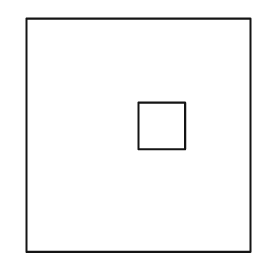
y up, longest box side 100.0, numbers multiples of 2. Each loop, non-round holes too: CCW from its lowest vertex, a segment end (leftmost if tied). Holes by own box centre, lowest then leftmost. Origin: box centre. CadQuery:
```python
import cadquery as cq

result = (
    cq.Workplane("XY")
    .moveTo(-48.0, -50.0)
    .lineTo(48.0, -50.0)
    .lineTo(48.0, 50.0)
    .lineTo(-48.0, 50.0)
    .close()
    .moveTo(0.0, -6.0)
    .lineTo(20.0, -6.0)
    .lineTo(20.0, 14.0)
    .lineTo(0.0, 14.0)
    .close()
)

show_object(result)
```